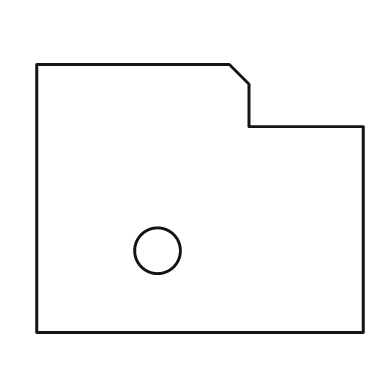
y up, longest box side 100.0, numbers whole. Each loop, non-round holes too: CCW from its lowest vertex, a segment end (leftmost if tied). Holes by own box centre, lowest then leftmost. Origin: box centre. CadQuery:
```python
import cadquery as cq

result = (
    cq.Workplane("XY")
    .moveTo(-50.0, -41.0)
    .lineTo(50.0, -41.0)
    .lineTo(50.0, 22.0)
    .lineTo(15.0, 22.0)
    .lineTo(15.0, 35.0)
    .lineTo(9.0, 41.0)
    .lineTo(-50.0, 41.0)
    .close()
    .moveTo(-13.0, -16.0)
    .circle(7.0)
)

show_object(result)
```